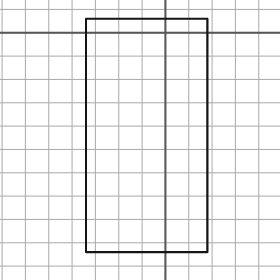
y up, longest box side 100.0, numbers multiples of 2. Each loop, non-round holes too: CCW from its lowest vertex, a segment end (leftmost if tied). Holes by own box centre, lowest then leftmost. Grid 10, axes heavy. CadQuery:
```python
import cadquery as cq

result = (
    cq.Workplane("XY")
    .moveTo(-34.0, -94.0)
    .lineTo(18.0, -94.0)
    .lineTo(18.0, 6.0)
    .lineTo(-34.0, 6.0)
    .close()
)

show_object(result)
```